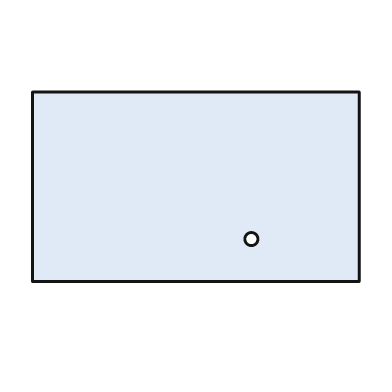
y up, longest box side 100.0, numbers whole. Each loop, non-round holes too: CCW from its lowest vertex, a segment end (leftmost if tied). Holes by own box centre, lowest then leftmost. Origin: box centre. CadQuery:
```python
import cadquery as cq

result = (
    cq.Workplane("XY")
    .moveTo(-50.0, -29.0)
    .lineTo(50.0, -29.0)
    .lineTo(50.0, 29.0)
    .lineTo(-50.0, 29.0)
    .close()
    .moveTo(17.0, -16.0)
    .circle(2.0)
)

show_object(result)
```